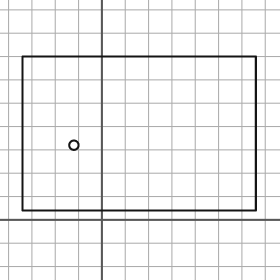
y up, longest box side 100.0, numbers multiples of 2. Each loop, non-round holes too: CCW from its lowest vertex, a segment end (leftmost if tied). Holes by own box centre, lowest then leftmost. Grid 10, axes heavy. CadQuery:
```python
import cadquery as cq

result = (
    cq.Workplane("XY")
    .moveTo(-34.0, 4.0)
    .lineTo(66.0, 4.0)
    .lineTo(66.0, 70.0)
    .lineTo(-34.0, 70.0)
    .close()
    .moveTo(-12.0, 32.0)
    .circle(2.0)
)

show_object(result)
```